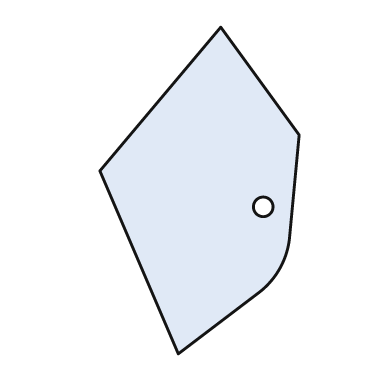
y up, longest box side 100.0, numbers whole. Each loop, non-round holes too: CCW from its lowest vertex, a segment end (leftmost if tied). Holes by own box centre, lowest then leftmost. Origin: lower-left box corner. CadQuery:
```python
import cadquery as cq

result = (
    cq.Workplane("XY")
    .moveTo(24.0, 0.0)
    .lineTo(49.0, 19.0)
    .threePointArc((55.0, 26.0), (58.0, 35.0))
    .lineTo(61.0, 67.0)
    .lineTo(37.0, 100.0)
    .lineTo(0.0, 56.0)
    .close()
    .moveTo(50.0, 45.0)
    .circle(3.0)
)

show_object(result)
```